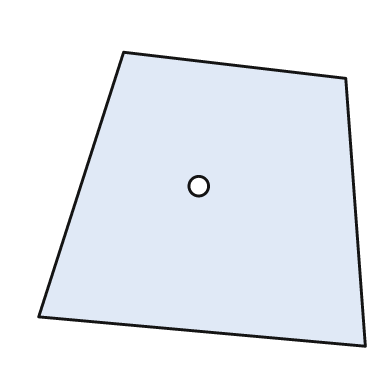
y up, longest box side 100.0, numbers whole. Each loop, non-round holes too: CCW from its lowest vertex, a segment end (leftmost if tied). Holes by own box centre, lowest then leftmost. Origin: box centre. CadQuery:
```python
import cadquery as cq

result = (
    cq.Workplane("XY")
    .moveTo(50.0, -45.0)
    .lineTo(44.0, 37.0)
    .lineTo(-24.0, 45.0)
    .lineTo(-50.0, -36.0)
    .close()
    .moveTo(-1.0, 4.0)
    .circle(3.0)
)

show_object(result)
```